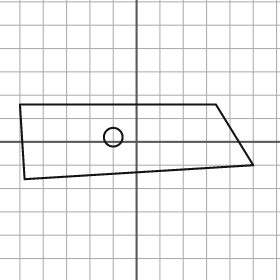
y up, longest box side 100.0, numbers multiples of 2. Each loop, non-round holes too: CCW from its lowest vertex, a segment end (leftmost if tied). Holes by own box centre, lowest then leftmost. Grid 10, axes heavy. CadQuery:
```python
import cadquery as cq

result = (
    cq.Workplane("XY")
    .moveTo(-48.0, -16.0)
    .lineTo(50.0, -10.0)
    .lineTo(34.0, 16.0)
    .lineTo(-50.0, 16.0)
    .close()
    .moveTo(-10.0, 2.0)
    .circle(4.0)
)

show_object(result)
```